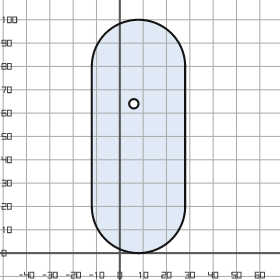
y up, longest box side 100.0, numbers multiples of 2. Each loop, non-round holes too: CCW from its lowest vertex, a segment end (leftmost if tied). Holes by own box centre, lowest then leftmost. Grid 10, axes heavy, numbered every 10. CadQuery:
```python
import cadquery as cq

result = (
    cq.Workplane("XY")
    .moveTo(-12.0, 20.0)
    .threePointArc((8.0, 0.0), (28.0, 20.0))
    .lineTo(28.0, 80.0)
    .threePointArc((8.0, 100.0), (-12.0, 80.0))
    .close()
    .moveTo(6.0, 64.0)
    .circle(2.0)
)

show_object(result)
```